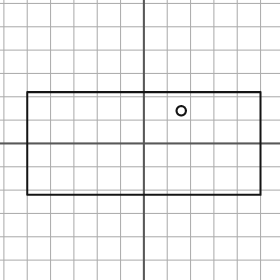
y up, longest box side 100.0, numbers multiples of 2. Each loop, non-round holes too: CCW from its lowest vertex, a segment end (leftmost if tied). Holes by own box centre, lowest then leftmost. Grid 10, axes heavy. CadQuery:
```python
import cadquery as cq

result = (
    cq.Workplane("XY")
    .moveTo(-50.0, -22.0)
    .lineTo(50.0, -22.0)
    .lineTo(50.0, 22.0)
    .lineTo(-50.0, 22.0)
    .close()
    .moveTo(16.0, 14.0)
    .circle(2.0)
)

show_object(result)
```